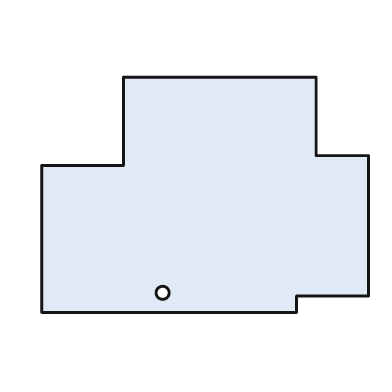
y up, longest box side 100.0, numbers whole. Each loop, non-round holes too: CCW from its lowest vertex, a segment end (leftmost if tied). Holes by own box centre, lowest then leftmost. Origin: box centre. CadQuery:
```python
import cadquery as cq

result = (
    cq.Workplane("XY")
    .moveTo(-50.0, -36.0)
    .lineTo(28.0, -36.0)
    .lineTo(28.0, -31.0)
    .lineTo(50.0, -31.0)
    .lineTo(50.0, 12.0)
    .lineTo(34.0, 12.0)
    .lineTo(34.0, 36.0)
    .lineTo(-25.0, 36.0)
    .lineTo(-25.0, 9.0)
    .lineTo(-50.0, 9.0)
    .close()
    .moveTo(-13.0, -30.0)
    .circle(2.0)
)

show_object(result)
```